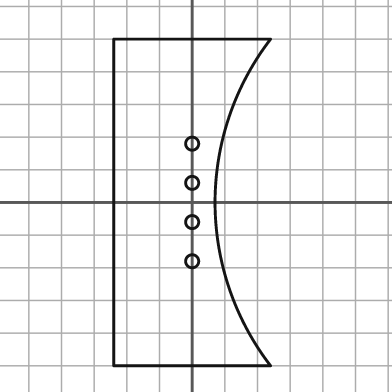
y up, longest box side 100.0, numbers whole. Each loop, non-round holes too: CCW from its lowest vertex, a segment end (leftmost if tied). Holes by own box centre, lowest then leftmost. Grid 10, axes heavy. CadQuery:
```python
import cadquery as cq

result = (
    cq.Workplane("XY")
    .moveTo(-24.0, -50.0)
    .lineTo(24.0, -50.0)
    .threePointArc((7.0, 0.0), (24.0, 50.0))
    .lineTo(-24.0, 50.0)
    .close()
    .moveTo(0.0, -18.0)
    .circle(2.0)
    .moveTo(0.0, -6.0)
    .circle(2.0)
    .moveTo(0.0, 6.0)
    .circle(2.0)
    .moveTo(0.0, 18.0)
    .circle(2.0)
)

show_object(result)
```